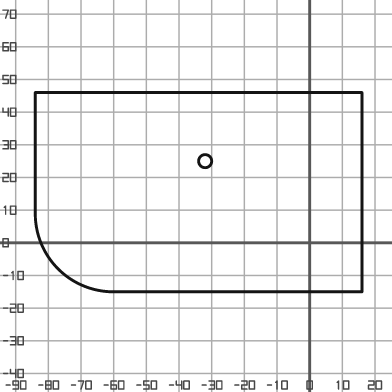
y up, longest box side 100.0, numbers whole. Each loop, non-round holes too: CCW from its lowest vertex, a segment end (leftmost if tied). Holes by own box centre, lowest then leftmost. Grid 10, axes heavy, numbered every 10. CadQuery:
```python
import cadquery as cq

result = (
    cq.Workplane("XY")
    .moveTo(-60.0, -15.0)
    .lineTo(16.0, -15.0)
    .lineTo(16.0, 46.0)
    .lineTo(-84.0, 46.0)
    .lineTo(-84.0, 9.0)
    .threePointArc((-77.0, -8.0), (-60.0, -15.0))
    .close()
    .moveTo(-32.0, 25.0)
    .circle(2.0)
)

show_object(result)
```